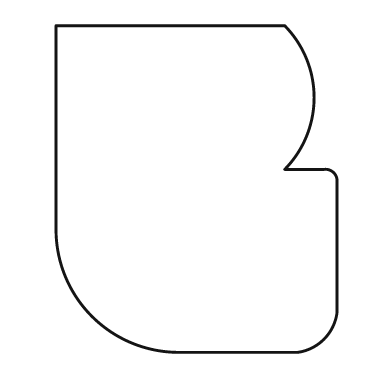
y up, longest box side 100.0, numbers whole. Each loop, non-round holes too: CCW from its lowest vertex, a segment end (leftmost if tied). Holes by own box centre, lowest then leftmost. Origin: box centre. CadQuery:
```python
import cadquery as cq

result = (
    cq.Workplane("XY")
    .moveTo(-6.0, -50.0)
    .lineTo(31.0, -50.0)
    .threePointArc((39.0, -46.0), (43.0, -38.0))
    .lineTo(43.0, 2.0)
    .threePointArc((42.0, 5.0), (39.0, 6.0))
    .lineTo(27.0, 6.0)
    .threePointArc((36.0, 28.0), (27.0, 50.0))
    .lineTo(-43.0, 50.0)
    .lineTo(-43.0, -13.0)
    .threePointArc((-32.0, -39.0), (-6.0, -50.0))
    .close()
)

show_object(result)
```